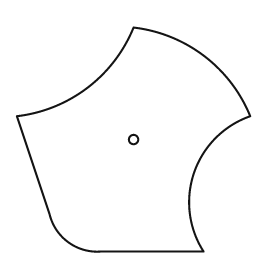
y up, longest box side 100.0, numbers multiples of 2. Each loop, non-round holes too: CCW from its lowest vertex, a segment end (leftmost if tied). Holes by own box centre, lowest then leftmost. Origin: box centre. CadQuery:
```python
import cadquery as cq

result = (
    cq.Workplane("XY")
    .moveTo(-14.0, -48.0)
    .lineTo(30.0, -48.0)
    .threePointArc((26.0, -14.0), (50.0, 10.0))
    .threePointArc((30.0, 36.0), (0.0, 48.0))
    .threePointArc((-20.0, 22.0), (-50.0, 10.0))
    .lineTo(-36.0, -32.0)
    .threePointArc((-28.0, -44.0), (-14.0, -48.0))
    .close()
    .moveTo(0.0, 0.0)
    .circle(2.0)
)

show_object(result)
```